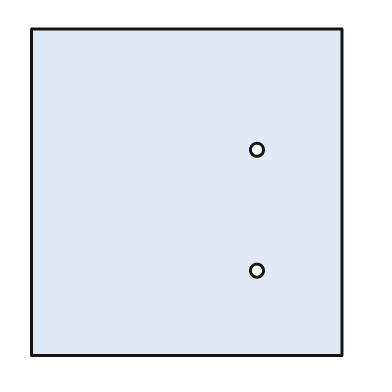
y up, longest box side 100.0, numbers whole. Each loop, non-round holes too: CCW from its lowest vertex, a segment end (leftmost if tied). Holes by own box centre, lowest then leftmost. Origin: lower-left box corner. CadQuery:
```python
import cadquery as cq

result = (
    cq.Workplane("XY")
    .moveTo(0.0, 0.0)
    .lineTo(95.0, 0.0)
    .lineTo(95.0, 100.0)
    .lineTo(0.0, 100.0)
    .close()
    .moveTo(69.0, 26.0)
    .circle(2.0)
    .moveTo(69.0, 63.0)
    .circle(2.0)
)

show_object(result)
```